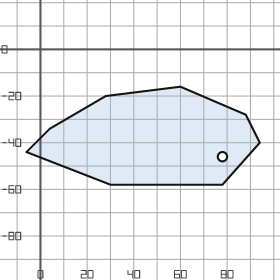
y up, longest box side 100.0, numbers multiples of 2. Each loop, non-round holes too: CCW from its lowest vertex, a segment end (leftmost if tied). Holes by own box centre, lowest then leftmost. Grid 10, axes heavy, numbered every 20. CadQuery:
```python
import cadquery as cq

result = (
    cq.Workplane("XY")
    .moveTo(30.0, -58.0)
    .lineTo(78.0, -58.0)
    .lineTo(94.0, -40.0)
    .lineTo(88.0, -28.0)
    .lineTo(60.0, -16.0)
    .lineTo(28.0, -20.0)
    .lineTo(4.0, -34.0)
    .lineTo(-6.0, -44.0)
    .close()
    .moveTo(78.0, -46.0)
    .circle(2.0)
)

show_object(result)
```